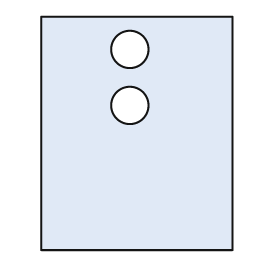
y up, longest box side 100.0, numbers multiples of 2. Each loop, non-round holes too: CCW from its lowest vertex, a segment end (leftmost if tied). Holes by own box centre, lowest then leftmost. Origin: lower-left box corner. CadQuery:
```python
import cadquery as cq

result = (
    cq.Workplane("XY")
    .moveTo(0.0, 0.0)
    .lineTo(82.0, 0.0)
    .lineTo(82.0, 100.0)
    .lineTo(0.0, 100.0)
    .close()
    .moveTo(38.0, 62.0)
    .circle(8.0)
    .moveTo(38.0, 86.0)
    .circle(8.0)
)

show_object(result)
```